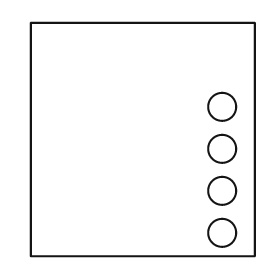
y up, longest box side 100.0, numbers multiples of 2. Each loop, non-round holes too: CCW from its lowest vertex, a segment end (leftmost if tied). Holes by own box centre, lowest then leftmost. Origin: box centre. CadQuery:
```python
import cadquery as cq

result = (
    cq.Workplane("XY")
    .moveTo(-48.0, -50.0)
    .lineTo(48.0, -50.0)
    .lineTo(48.0, 50.0)
    .lineTo(-48.0, 50.0)
    .close()
    .moveTo(34.0, -40.0)
    .circle(6.0)
    .moveTo(34.0, -22.0)
    .circle(6.0)
    .moveTo(34.0, -4.0)
    .circle(6.0)
    .moveTo(34.0, 14.0)
    .circle(6.0)
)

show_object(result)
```